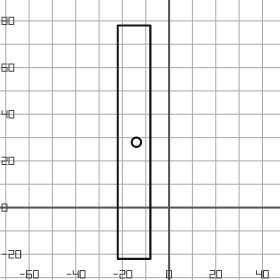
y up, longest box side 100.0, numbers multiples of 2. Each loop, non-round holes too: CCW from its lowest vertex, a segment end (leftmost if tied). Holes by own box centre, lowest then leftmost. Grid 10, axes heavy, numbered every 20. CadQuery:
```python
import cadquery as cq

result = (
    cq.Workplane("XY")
    .moveTo(-22.0, -22.0)
    .lineTo(-8.0, -22.0)
    .lineTo(-8.0, 78.0)
    .lineTo(-22.0, 78.0)
    .close()
    .moveTo(-14.0, 28.0)
    .circle(2.0)
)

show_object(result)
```